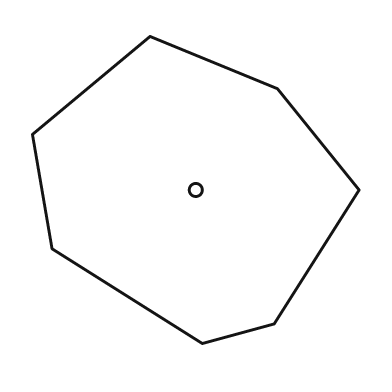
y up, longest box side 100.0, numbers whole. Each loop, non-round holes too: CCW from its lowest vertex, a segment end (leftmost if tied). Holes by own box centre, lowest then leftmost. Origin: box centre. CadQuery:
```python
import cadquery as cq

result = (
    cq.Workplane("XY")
    .moveTo(2.0, -47.0)
    .lineTo(24.0, -41.0)
    .lineTo(50.0, 0.0)
    .lineTo(25.0, 31.0)
    .lineTo(-14.0, 47.0)
    .lineTo(-50.0, 17.0)
    .lineTo(-44.0, -18.0)
    .close()
    .moveTo(0.0, 0.0)
    .circle(2.0)
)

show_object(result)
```